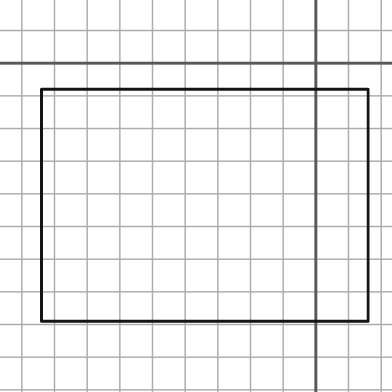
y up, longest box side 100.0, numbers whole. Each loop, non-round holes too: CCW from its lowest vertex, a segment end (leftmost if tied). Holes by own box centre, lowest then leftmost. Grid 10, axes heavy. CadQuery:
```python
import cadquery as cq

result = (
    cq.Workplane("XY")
    .moveTo(-84.0, -79.0)
    .lineTo(16.0, -79.0)
    .lineTo(16.0, -8.0)
    .lineTo(-84.0, -8.0)
    .close()
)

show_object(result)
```